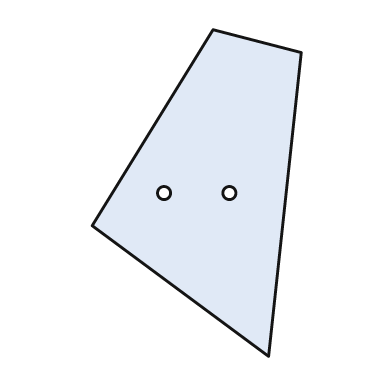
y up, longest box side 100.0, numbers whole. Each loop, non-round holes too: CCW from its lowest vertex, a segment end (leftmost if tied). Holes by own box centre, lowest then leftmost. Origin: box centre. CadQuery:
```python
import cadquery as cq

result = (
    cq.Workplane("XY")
    .moveTo(22.0, -50.0)
    .lineTo(32.0, 43.0)
    .lineTo(5.0, 50.0)
    .lineTo(-32.0, -10.0)
    .close()
    .moveTo(-10.0, 0.0)
    .circle(2.0)
    .moveTo(10.0, 0.0)
    .circle(2.0)
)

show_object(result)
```